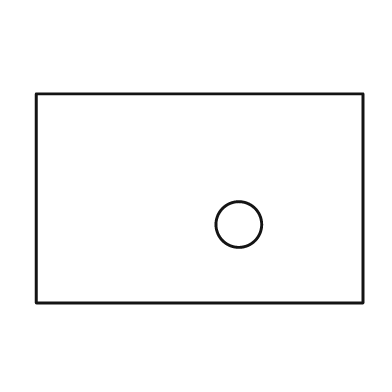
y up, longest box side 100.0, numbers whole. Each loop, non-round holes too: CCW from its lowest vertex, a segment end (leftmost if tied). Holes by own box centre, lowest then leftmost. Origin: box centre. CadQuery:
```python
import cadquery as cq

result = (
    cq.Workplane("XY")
    .moveTo(-50.0, -32.0)
    .lineTo(50.0, -32.0)
    .lineTo(50.0, 32.0)
    .lineTo(-50.0, 32.0)
    .close()
    .moveTo(12.0, -8.0)
    .circle(7.0)
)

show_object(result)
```